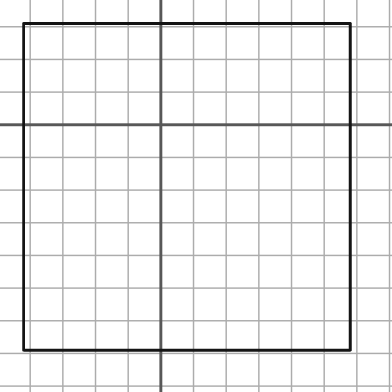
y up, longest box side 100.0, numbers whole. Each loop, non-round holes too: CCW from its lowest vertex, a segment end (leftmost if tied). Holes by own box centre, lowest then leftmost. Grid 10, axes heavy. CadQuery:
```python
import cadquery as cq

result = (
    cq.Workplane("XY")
    .moveTo(-42.0, -69.0)
    .lineTo(58.0, -69.0)
    .lineTo(58.0, 31.0)
    .lineTo(-42.0, 31.0)
    .close()
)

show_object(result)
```